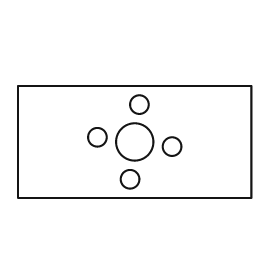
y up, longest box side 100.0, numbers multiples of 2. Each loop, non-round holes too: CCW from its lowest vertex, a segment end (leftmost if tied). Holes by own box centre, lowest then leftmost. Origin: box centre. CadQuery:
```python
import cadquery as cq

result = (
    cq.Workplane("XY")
    .moveTo(-50.0, -24.0)
    .lineTo(50.0, -24.0)
    .lineTo(50.0, 24.0)
    .lineTo(-50.0, 24.0)
    .close()
    .moveTo(-2.0, -16.0)
    .circle(4.0)
    .moveTo(16.0, -2.0)
    .circle(4.0)
    .moveTo(0.0, 0.0)
    .circle(8.0)
    .moveTo(-16.0, 2.0)
    .circle(4.0)
    .moveTo(2.0, 16.0)
    .circle(4.0)
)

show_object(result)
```